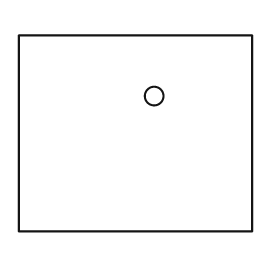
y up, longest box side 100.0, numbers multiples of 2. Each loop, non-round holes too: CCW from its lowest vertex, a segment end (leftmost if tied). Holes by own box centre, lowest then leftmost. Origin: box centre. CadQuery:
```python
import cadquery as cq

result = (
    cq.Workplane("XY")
    .moveTo(-50.0, -42.0)
    .lineTo(50.0, -42.0)
    .lineTo(50.0, 42.0)
    .lineTo(-50.0, 42.0)
    .close()
    .moveTo(8.0, 16.0)
    .circle(4.0)
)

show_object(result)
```